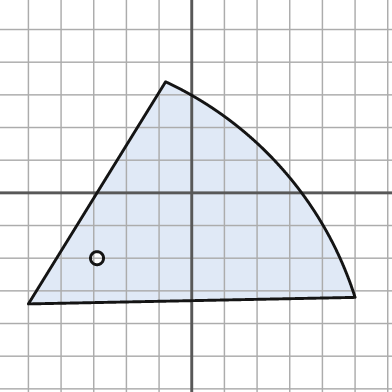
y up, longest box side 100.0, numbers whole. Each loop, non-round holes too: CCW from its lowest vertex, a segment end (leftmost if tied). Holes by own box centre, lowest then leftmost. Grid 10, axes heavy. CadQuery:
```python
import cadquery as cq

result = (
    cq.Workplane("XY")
    .moveTo(-50.0, -34.0)
    .lineTo(50.0, -32.0)
    .threePointArc((28.0, 7.0), (-8.0, 34.0))
    .close()
    .moveTo(-29.0, -20.0)
    .circle(2.0)
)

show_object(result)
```